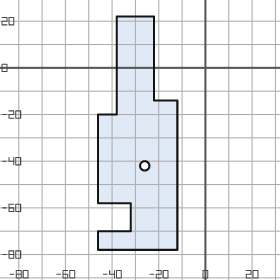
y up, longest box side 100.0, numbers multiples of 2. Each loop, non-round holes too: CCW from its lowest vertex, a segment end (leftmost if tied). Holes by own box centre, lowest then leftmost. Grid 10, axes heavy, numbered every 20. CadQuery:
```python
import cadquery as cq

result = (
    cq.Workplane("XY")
    .moveTo(-46.0, -78.0)
    .lineTo(-12.0, -78.0)
    .lineTo(-12.0, -14.0)
    .lineTo(-22.0, -14.0)
    .lineTo(-22.0, 22.0)
    .lineTo(-38.0, 22.0)
    .lineTo(-38.0, -20.0)
    .lineTo(-46.0, -20.0)
    .lineTo(-46.0, -58.0)
    .lineTo(-32.0, -58.0)
    .lineTo(-32.0, -70.0)
    .lineTo(-46.0, -70.0)
    .close()
    .moveTo(-26.0, -42.0)
    .circle(2.0)
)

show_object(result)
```